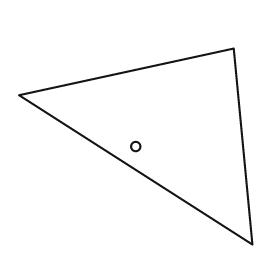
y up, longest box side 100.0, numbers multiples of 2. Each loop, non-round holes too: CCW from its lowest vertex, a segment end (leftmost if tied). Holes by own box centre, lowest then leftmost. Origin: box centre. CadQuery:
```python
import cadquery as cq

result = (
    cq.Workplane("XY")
    .moveTo(50.0, -42.0)
    .lineTo(42.0, 42.0)
    .lineTo(-50.0, 22.0)
    .close()
    .moveTo(0.0, 0.0)
    .circle(2.0)
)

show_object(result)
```